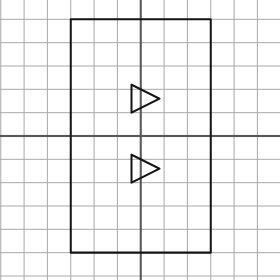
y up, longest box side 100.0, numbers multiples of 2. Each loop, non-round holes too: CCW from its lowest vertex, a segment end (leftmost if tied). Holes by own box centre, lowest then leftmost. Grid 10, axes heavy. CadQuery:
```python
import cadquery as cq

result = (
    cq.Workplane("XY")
    .moveTo(-30.0, -50.0)
    .lineTo(30.0, -50.0)
    .lineTo(30.0, 50.0)
    .lineTo(-30.0, 50.0)
    .close()
    .moveTo(-4.0, -20.0)
    .lineTo(8.0, -14.0)
    .lineTo(-4.0, -8.0)
    .close()
    .moveTo(-4.0, 10.0)
    .lineTo(8.0, 16.0)
    .lineTo(-4.0, 22.0)
    .close()
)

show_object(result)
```